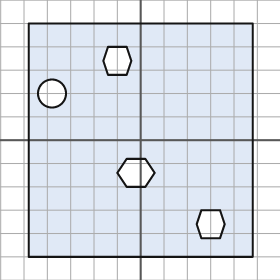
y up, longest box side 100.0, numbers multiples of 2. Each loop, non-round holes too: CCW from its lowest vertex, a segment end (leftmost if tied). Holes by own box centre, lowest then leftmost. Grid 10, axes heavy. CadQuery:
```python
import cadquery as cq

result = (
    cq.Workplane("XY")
    .moveTo(-48.0, -50.0)
    .lineTo(48.0, -50.0)
    .lineTo(48.0, 50.0)
    .lineTo(-48.0, 50.0)
    .close()
    .moveTo(26.0, -42.0)
    .lineTo(34.0, -42.0)
    .lineTo(36.0, -36.0)
    .lineTo(34.0, -30.0)
    .lineTo(26.0, -30.0)
    .lineTo(24.0, -36.0)
    .close()
    .moveTo(-6.0, -20.0)
    .lineTo(2.0, -20.0)
    .lineTo(6.0, -14.0)
    .lineTo(2.0, -8.0)
    .lineTo(-6.0, -8.0)
    .lineTo(-10.0, -14.0)
    .close()
    .moveTo(-38.0, 20.0)
    .circle(6.0)
    .moveTo(-14.0, 28.0)
    .lineTo(-6.0, 28.0)
    .lineTo(-4.0, 34.0)
    .lineTo(-6.0, 40.0)
    .lineTo(-14.0, 40.0)
    .lineTo(-16.0, 34.0)
    .close()
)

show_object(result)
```